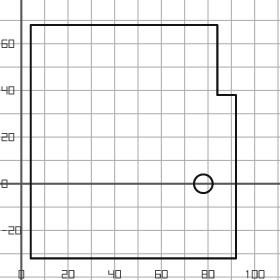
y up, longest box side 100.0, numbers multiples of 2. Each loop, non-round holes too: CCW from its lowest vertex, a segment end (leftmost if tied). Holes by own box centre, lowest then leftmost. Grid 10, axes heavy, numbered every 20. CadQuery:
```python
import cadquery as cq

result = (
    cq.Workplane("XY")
    .moveTo(4.0, -32.0)
    .lineTo(92.0, -32.0)
    .lineTo(92.0, 38.0)
    .lineTo(84.0, 38.0)
    .lineTo(84.0, 68.0)
    .lineTo(4.0, 68.0)
    .close()
    .moveTo(78.0, 0.0)
    .circle(4.0)
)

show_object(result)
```